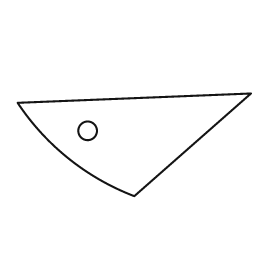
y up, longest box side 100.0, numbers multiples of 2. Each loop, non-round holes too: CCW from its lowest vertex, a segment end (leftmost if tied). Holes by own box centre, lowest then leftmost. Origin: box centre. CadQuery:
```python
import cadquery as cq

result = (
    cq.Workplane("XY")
    .moveTo(0.0, -22.0)
    .lineTo(50.0, 22.0)
    .lineTo(-50.0, 18.0)
    .threePointArc((-28.0, -6.0), (0.0, -22.0))
    .close()
    .moveTo(-20.0, 6.0)
    .circle(4.0)
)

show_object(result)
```